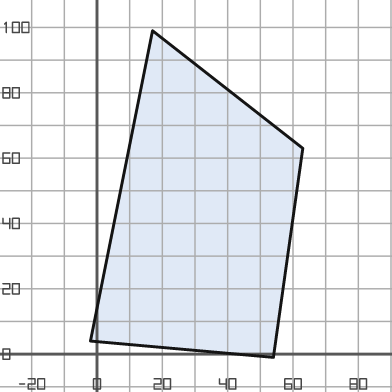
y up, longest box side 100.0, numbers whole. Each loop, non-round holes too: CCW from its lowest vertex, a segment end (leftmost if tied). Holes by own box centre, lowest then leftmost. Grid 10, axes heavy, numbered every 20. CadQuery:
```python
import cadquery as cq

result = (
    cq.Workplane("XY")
    .moveTo(54.0, -1.0)
    .lineTo(63.0, 63.0)
    .lineTo(17.0, 99.0)
    .lineTo(-2.0, 4.0)
    .close()
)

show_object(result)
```